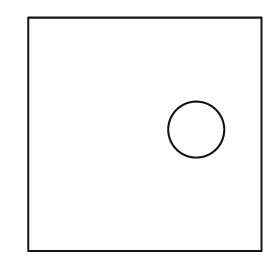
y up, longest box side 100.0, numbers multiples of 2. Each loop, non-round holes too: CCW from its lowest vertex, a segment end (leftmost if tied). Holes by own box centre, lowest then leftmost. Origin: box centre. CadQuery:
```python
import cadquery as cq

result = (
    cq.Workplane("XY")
    .moveTo(-50.0, -50.0)
    .lineTo(50.0, -50.0)
    .lineTo(50.0, 50.0)
    .lineTo(-50.0, 50.0)
    .close()
    .moveTo(22.0, 2.0)
    .circle(12.0)
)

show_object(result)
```